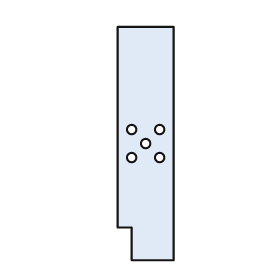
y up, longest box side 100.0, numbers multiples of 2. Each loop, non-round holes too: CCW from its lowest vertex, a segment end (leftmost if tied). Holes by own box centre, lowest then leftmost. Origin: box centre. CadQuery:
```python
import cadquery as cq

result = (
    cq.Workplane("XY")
    .moveTo(-6.0, -50.0)
    .lineTo(12.0, -50.0)
    .lineTo(12.0, 50.0)
    .lineTo(-12.0, 50.0)
    .lineTo(-12.0, -36.0)
    .lineTo(-6.0, -36.0)
    .close()
    .moveTo(-6.0, -6.0)
    .circle(2.0)
    .moveTo(6.0, -6.0)
    .circle(2.0)
    .moveTo(0.0, 0.0)
    .circle(2.0)
    .moveTo(-6.0, 6.0)
    .circle(2.0)
    .moveTo(6.0, 6.0)
    .circle(2.0)
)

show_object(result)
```